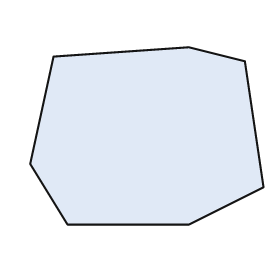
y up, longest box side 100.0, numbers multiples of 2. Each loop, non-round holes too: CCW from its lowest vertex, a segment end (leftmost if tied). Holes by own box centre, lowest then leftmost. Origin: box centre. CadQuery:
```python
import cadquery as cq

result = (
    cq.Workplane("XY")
    .moveTo(-34.0, -38.0)
    .lineTo(18.0, -38.0)
    .lineTo(50.0, -22.0)
    .lineTo(42.0, 32.0)
    .lineTo(18.0, 38.0)
    .lineTo(-40.0, 34.0)
    .lineTo(-50.0, -12.0)
    .close()
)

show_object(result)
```